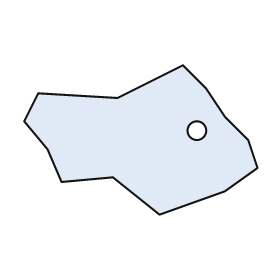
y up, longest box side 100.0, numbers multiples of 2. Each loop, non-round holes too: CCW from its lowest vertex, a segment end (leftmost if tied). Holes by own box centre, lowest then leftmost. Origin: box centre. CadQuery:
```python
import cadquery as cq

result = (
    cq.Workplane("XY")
    .moveTo(8.0, -32.0)
    .lineTo(36.0, -22.0)
    .lineTo(50.0, -12.0)
    .lineTo(46.0, 0.0)
    .lineTo(36.0, 10.0)
    .lineTo(28.0, 22.0)
    .lineTo(18.0, 32.0)
    .lineTo(-10.0, 18.0)
    .lineTo(-44.0, 20.0)
    .lineTo(-50.0, 8.0)
    .lineTo(-40.0, -4.0)
    .lineTo(-34.0, -18.0)
    .lineTo(-12.0, -16.0)
    .close()
    .moveTo(24.0, 4.0)
    .circle(4.0)
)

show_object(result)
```